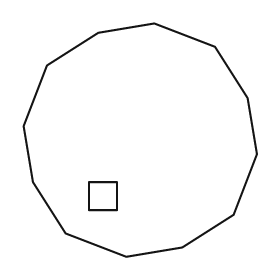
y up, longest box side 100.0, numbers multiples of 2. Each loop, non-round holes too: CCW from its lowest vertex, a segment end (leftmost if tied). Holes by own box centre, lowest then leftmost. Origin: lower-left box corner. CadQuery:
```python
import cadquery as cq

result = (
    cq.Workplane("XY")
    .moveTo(44.0, 0.0)
    .lineTo(68.0, 4.0)
    .lineTo(90.0, 18.0)
    .lineTo(100.0, 44.0)
    .lineTo(96.0, 68.0)
    .lineTo(82.0, 90.0)
    .lineTo(56.0, 100.0)
    .lineTo(32.0, 96.0)
    .lineTo(10.0, 82.0)
    .lineTo(0.0, 56.0)
    .lineTo(4.0, 32.0)
    .lineTo(18.0, 10.0)
    .close()
    .moveTo(28.0, 20.0)
    .lineTo(40.0, 20.0)
    .lineTo(40.0, 32.0)
    .lineTo(28.0, 32.0)
    .close()
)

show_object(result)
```